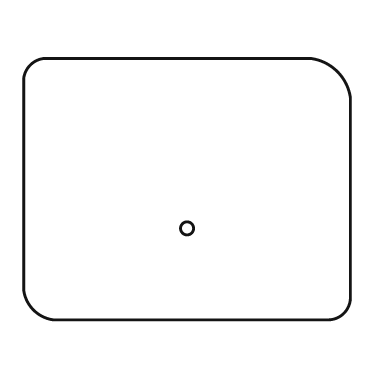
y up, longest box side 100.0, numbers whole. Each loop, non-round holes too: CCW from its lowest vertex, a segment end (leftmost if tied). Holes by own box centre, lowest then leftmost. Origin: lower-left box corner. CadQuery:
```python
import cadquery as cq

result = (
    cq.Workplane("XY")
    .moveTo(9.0, 0.0)
    .lineTo(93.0, 0.0)
    .threePointArc((98.0, 2.0), (100.0, 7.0))
    .lineTo(100.0, 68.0)
    .threePointArc((96.0, 76.0), (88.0, 80.0))
    .lineTo(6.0, 80.0)
    .threePointArc((2.0, 78.0), (0.0, 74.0))
    .lineTo(0.0, 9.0)
    .threePointArc((3.0, 3.0), (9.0, 0.0))
    .close()
    .moveTo(50.0, 28.0)
    .circle(2.0)
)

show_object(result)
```